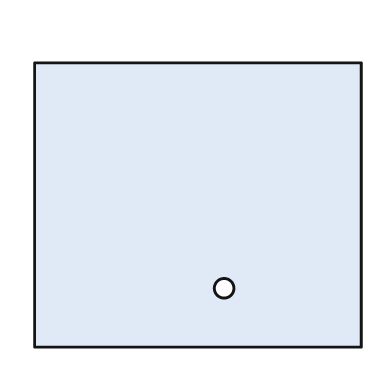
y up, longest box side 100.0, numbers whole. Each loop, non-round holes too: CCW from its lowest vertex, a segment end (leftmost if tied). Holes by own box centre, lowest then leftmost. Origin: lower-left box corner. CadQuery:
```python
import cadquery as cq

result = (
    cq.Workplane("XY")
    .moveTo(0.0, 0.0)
    .lineTo(100.0, 0.0)
    .lineTo(100.0, 87.0)
    .lineTo(0.0, 87.0)
    .close()
    .moveTo(58.0, 18.0)
    .circle(3.0)
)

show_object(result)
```